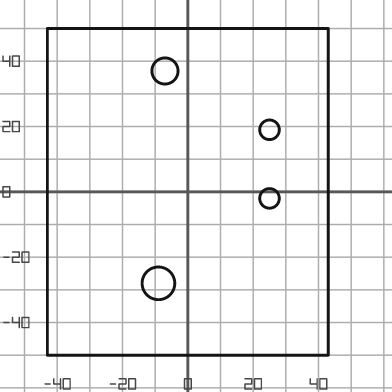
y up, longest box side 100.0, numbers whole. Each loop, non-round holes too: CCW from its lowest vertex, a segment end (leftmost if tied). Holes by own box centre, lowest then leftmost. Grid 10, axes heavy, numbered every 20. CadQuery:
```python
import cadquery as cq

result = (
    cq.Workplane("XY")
    .moveTo(-43.0, -50.0)
    .lineTo(43.0, -50.0)
    .lineTo(43.0, 50.0)
    .lineTo(-43.0, 50.0)
    .close()
    .moveTo(-9.0, -28.0)
    .circle(5.0)
    .moveTo(25.0, -2.0)
    .circle(3.0)
    .moveTo(25.0, 19.0)
    .circle(3.0)
    .moveTo(-7.0, 37.0)
    .circle(4.0)
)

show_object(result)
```